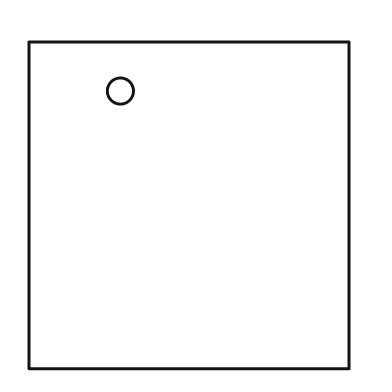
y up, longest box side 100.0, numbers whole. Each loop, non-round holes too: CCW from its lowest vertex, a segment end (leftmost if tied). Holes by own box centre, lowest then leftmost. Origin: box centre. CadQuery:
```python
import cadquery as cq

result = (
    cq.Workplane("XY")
    .moveTo(-49.0, -50.0)
    .lineTo(49.0, -50.0)
    .lineTo(49.0, 50.0)
    .lineTo(-49.0, 50.0)
    .close()
    .moveTo(-21.0, 35.0)
    .circle(4.0)
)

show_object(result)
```